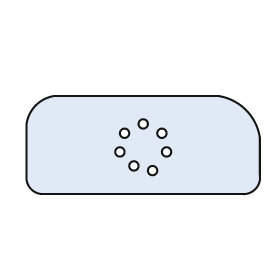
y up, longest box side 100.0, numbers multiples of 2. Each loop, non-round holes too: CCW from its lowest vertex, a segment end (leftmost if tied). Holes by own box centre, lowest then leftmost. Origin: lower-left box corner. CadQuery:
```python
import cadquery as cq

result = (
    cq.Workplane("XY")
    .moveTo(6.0, 0.0)
    .lineTo(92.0, 0.0)
    .threePointArc((98.0, 2.0), (100.0, 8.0))
    .lineTo(100.0, 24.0)
    .threePointArc((94.0, 36.0), (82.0, 42.0))
    .lineTo(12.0, 42.0)
    .threePointArc((4.0, 38.0), (0.0, 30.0))
    .lineTo(0.0, 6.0)
    .threePointArc((2.0, 2.0), (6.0, 0.0))
    .close()
    .moveTo(54.0, 10.0)
    .circle(2.0)
    .moveTo(46.0, 12.0)
    .circle(2.0)
    .moveTo(40.0, 18.0)
    .circle(2.0)
    .moveTo(60.0, 18.0)
    .circle(2.0)
    .moveTo(42.0, 26.0)
    .circle(2.0)
    .moveTo(58.0, 26.0)
    .circle(2.0)
    .moveTo(50.0, 30.0)
    .circle(2.0)
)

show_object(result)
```